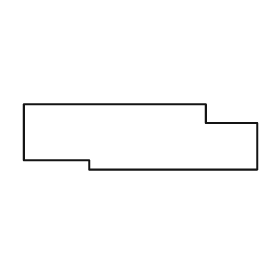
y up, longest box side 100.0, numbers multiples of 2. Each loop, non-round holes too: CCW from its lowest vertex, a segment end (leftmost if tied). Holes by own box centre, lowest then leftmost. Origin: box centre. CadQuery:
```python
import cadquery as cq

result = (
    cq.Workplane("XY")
    .moveTo(-22.0, -14.0)
    .lineTo(50.0, -14.0)
    .lineTo(50.0, 6.0)
    .lineTo(28.0, 6.0)
    .lineTo(28.0, 14.0)
    .lineTo(-50.0, 14.0)
    .lineTo(-50.0, -10.0)
    .lineTo(-22.0, -10.0)
    .close()
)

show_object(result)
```